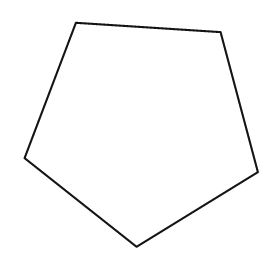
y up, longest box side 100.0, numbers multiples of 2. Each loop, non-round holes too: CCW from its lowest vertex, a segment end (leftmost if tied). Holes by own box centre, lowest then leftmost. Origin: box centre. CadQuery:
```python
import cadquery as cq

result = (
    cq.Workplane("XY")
    .moveTo(-2.0, -48.0)
    .lineTo(50.0, -16.0)
    .lineTo(34.0, 44.0)
    .lineTo(-28.0, 48.0)
    .lineTo(-50.0, -10.0)
    .close()
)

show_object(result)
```